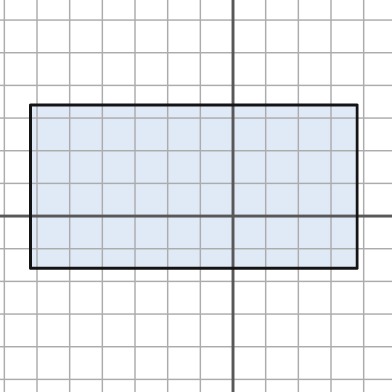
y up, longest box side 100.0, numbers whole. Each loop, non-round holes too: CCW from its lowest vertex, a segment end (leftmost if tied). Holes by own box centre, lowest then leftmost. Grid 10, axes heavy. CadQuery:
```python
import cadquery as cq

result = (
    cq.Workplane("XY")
    .moveTo(-62.0, -16.0)
    .lineTo(38.0, -16.0)
    .lineTo(38.0, 34.0)
    .lineTo(-62.0, 34.0)
    .close()
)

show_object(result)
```